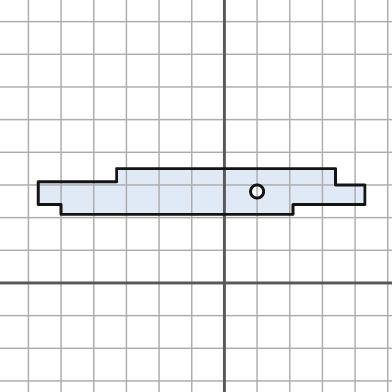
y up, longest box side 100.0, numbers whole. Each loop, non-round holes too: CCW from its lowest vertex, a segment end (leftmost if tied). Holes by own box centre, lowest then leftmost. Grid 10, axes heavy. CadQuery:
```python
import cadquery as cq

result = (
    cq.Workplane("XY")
    .moveTo(-50.0, 21.0)
    .lineTo(21.0, 21.0)
    .lineTo(21.0, 24.0)
    .lineTo(43.0, 24.0)
    .lineTo(43.0, 30.0)
    .lineTo(34.0, 30.0)
    .lineTo(34.0, 35.0)
    .lineTo(-33.0, 35.0)
    .lineTo(-33.0, 31.0)
    .lineTo(-57.0, 31.0)
    .lineTo(-57.0, 24.0)
    .lineTo(-50.0, 24.0)
    .close()
    .moveTo(10.0, 28.0)
    .circle(2.0)
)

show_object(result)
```